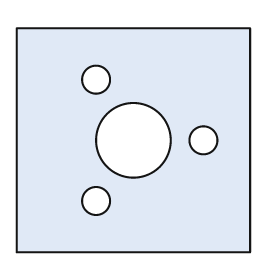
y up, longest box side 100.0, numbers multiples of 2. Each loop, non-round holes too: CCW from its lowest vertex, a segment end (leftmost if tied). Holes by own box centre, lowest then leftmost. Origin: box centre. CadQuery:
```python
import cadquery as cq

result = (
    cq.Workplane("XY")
    .moveTo(-50.0, -48.0)
    .lineTo(50.0, -48.0)
    .lineTo(50.0, 48.0)
    .lineTo(-50.0, 48.0)
    .close()
    .moveTo(-16.0, -26.0)
    .circle(6.0)
    .moveTo(0.0, 0.0)
    .circle(16.0)
    .moveTo(30.0, 0.0)
    .circle(6.0)
    .moveTo(-16.0, 26.0)
    .circle(6.0)
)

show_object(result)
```